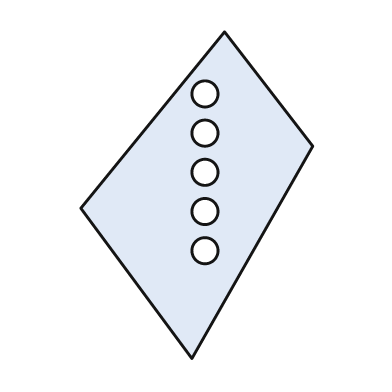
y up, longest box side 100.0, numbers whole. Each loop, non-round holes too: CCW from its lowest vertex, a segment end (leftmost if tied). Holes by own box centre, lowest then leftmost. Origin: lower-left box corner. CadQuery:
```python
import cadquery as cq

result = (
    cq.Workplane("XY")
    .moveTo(34.0, 0.0)
    .lineTo(71.0, 65.0)
    .lineTo(44.0, 100.0)
    .lineTo(0.0, 46.0)
    .close()
    .moveTo(38.0, 33.0)
    .circle(4.0)
    .moveTo(38.0, 45.0)
    .circle(4.0)
    .moveTo(38.0, 57.0)
    .circle(4.0)
    .moveTo(38.0, 69.0)
    .circle(4.0)
    .moveTo(38.0, 81.0)
    .circle(4.0)
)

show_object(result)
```